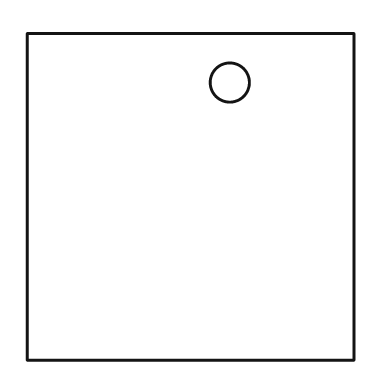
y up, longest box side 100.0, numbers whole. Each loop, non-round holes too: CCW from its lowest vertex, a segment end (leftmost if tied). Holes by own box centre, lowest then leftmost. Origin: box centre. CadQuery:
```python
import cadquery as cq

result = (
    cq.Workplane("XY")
    .moveTo(-50.0, -50.0)
    .lineTo(50.0, -50.0)
    .lineTo(50.0, 50.0)
    .lineTo(-50.0, 50.0)
    .close()
    .moveTo(12.0, 35.0)
    .circle(6.0)
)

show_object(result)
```